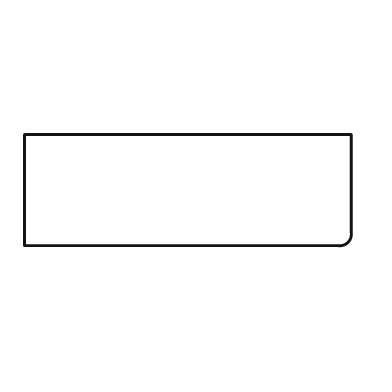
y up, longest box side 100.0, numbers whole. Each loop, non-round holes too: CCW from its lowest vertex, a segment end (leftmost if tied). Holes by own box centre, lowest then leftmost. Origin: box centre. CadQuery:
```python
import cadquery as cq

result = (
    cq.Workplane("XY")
    .moveTo(-50.0, -17.0)
    .lineTo(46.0, -17.0)
    .threePointArc((49.0, -16.0), (50.0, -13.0))
    .lineTo(50.0, 17.0)
    .lineTo(-50.0, 17.0)
    .close()
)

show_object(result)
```